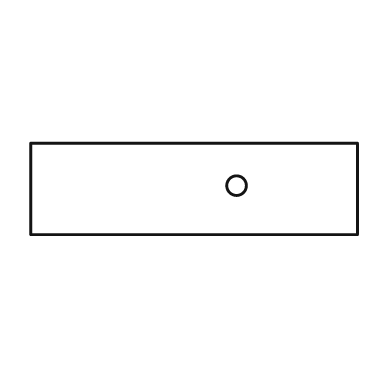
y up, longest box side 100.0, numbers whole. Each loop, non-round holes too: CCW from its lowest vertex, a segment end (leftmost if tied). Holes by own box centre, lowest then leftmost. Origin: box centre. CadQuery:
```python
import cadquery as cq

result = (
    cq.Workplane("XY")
    .moveTo(-50.0, -14.0)
    .lineTo(50.0, -14.0)
    .lineTo(50.0, 14.0)
    .lineTo(-50.0, 14.0)
    .close()
    .moveTo(13.0, 1.0)
    .circle(3.0)
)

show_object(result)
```